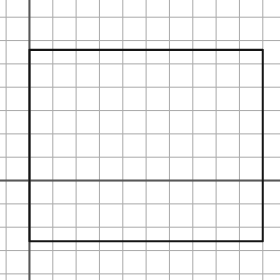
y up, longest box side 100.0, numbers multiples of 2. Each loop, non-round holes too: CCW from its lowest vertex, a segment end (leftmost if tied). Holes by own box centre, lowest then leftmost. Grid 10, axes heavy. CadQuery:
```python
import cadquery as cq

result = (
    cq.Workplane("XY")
    .moveTo(0.0, -26.0)
    .lineTo(100.0, -26.0)
    .lineTo(100.0, 56.0)
    .lineTo(0.0, 56.0)
    .close()
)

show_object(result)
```